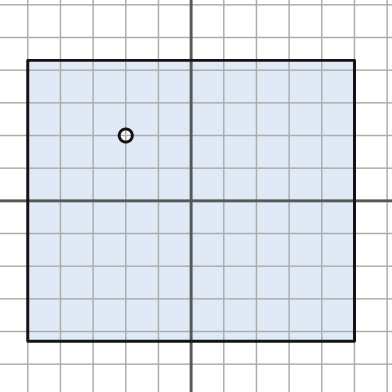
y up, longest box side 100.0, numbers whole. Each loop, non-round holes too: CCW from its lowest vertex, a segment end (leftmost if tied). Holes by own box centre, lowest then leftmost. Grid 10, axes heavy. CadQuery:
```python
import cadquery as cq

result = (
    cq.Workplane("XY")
    .moveTo(-50.0, -43.0)
    .lineTo(50.0, -43.0)
    .lineTo(50.0, 43.0)
    .lineTo(-50.0, 43.0)
    .close()
    .moveTo(-20.0, 20.0)
    .circle(2.0)
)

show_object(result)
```